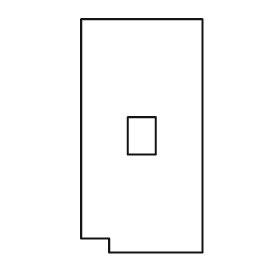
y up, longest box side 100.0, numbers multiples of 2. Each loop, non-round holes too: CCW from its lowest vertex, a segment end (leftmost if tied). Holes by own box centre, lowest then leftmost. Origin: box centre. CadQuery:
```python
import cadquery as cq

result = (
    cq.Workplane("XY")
    .moveTo(-14.0, -50.0)
    .lineTo(26.0, -50.0)
    .lineTo(26.0, 50.0)
    .lineTo(-26.0, 50.0)
    .lineTo(-26.0, -44.0)
    .lineTo(-14.0, -44.0)
    .close()
    .moveTo(-6.0, -8.0)
    .lineTo(6.0, -8.0)
    .lineTo(6.0, 8.0)
    .lineTo(-6.0, 8.0)
    .close()
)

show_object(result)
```